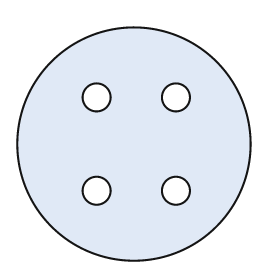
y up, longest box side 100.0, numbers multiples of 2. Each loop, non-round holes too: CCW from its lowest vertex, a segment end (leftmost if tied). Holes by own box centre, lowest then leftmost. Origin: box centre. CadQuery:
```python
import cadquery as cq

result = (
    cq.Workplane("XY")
    .moveTo(0.0, 0.0)
    .circle(50.0)
    .moveTo(-16.0, -20.0)
    .circle(6.0)
    .moveTo(18.0, -20.0)
    .circle(6.0)
    .moveTo(-16.0, 20.0)
    .circle(6.0)
    .moveTo(18.0, 20.0)
    .circle(6.0)
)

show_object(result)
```